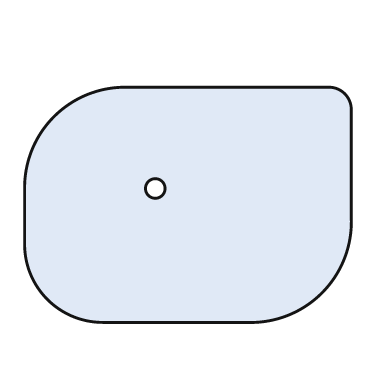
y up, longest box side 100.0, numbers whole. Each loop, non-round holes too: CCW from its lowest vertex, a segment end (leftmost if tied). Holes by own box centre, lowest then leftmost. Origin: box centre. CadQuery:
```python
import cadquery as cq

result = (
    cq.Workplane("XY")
    .moveTo(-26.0, -36.0)
    .lineTo(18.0, -36.0)
    .threePointArc((41.0, -27.0), (50.0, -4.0))
    .lineTo(50.0, 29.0)
    .threePointArc((48.0, 34.0), (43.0, 36.0))
    .lineTo(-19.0, 36.0)
    .threePointArc((-41.0, 27.0), (-50.0, 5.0))
    .lineTo(-50.0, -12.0)
    .threePointArc((-43.0, -29.0), (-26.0, -36.0))
    .close()
    .moveTo(-10.0, 5.0)
    .circle(3.0)
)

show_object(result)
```